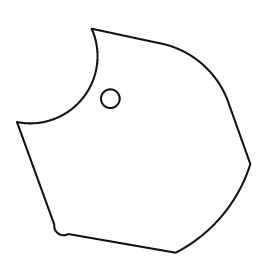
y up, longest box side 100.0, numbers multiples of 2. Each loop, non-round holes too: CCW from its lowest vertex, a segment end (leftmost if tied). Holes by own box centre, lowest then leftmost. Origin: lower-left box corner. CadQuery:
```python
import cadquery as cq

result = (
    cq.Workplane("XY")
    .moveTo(68.0, 0.0)
    .threePointArc((88.0, 16.0), (100.0, 38.0))
    .lineTo(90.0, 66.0)
    .threePointArc((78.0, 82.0), (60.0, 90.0))
    .lineTo(32.0, 96.0)
    .threePointArc((28.0, 66.0), (0.0, 56.0))
    .lineTo(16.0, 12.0)
    .threePointArc((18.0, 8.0), (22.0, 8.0))
    .close()
    .moveTo(40.0, 66.0)
    .circle(4.0)
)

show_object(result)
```